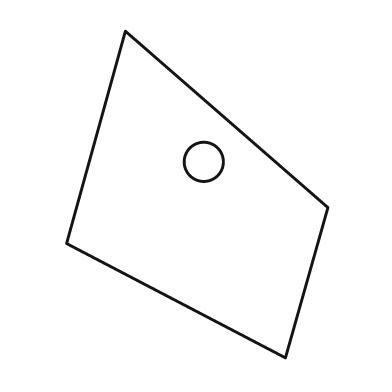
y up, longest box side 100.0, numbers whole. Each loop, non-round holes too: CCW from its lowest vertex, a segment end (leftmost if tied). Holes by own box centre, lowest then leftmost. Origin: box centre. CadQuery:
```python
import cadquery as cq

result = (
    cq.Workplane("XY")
    .moveTo(27.0, -50.0)
    .lineTo(40.0, -4.0)
    .lineTo(-22.0, 50.0)
    .lineTo(-40.0, -15.0)
    .close()
    .moveTo(2.0, 10.0)
    .circle(6.0)
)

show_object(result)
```